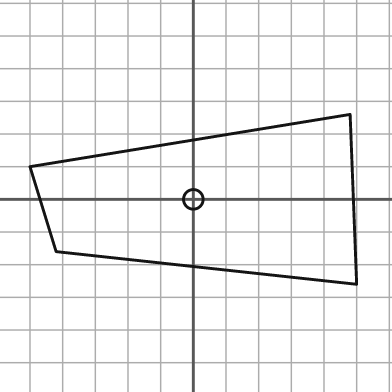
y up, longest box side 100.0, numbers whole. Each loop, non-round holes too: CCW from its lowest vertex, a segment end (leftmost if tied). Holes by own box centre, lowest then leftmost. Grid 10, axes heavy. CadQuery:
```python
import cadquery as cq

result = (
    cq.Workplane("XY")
    .moveTo(50.0, -26.0)
    .lineTo(48.0, 26.0)
    .lineTo(-50.0, 10.0)
    .lineTo(-42.0, -16.0)
    .close()
    .moveTo(0.0, 0.0)
    .circle(3.0)
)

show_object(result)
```